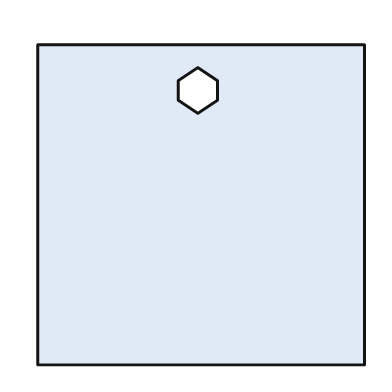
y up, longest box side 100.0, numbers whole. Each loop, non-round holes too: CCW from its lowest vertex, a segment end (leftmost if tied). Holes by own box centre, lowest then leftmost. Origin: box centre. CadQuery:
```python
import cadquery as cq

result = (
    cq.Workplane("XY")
    .moveTo(-50.0, -49.0)
    .lineTo(50.0, -49.0)
    .lineTo(50.0, 49.0)
    .lineTo(-50.0, 49.0)
    .close()
    .moveTo(-1.0, 28.0)
    .lineTo(5.0, 32.0)
    .lineTo(5.0, 38.0)
    .lineTo(-1.0, 42.0)
    .lineTo(-7.0, 38.0)
    .lineTo(-7.0, 32.0)
    .close()
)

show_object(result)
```